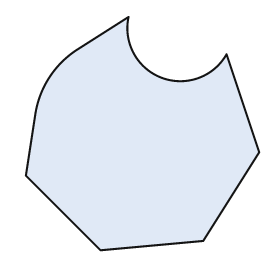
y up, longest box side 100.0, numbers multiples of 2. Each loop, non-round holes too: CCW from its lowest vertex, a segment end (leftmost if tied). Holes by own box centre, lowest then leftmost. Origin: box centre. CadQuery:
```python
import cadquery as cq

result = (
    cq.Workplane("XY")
    .moveTo(-18.0, -50.0)
    .lineTo(26.0, -46.0)
    .lineTo(50.0, -8.0)
    .lineTo(36.0, 34.0)
    .threePointArc((8.0, 24.0), (-6.0, 50.0))
    .lineTo(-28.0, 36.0)
    .threePointArc((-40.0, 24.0), (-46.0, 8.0))
    .lineTo(-50.0, -18.0)
    .close()
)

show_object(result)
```